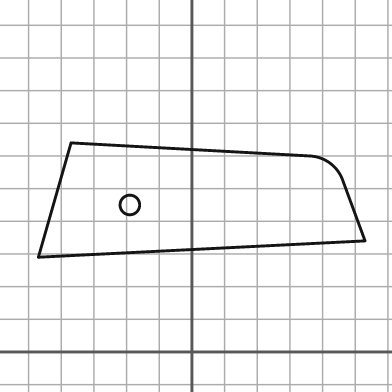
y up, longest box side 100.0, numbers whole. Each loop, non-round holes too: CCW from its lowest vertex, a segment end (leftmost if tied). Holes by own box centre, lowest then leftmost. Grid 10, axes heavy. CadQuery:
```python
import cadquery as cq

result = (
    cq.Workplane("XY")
    .moveTo(-47.0, 29.0)
    .lineTo(53.0, 34.0)
    .lineTo(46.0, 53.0)
    .threePointArc((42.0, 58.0), (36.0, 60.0))
    .lineTo(-37.0, 64.0)
    .close()
    .moveTo(-19.0, 45.0)
    .circle(3.0)
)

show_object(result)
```